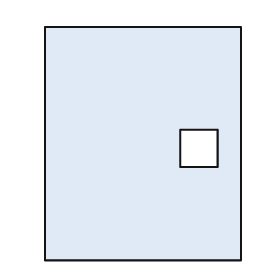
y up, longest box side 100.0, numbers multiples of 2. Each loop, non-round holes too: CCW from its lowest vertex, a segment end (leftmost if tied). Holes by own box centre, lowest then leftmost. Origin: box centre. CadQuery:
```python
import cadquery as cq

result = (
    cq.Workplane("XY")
    .moveTo(-42.0, -50.0)
    .lineTo(42.0, -50.0)
    .lineTo(42.0, 50.0)
    .lineTo(-42.0, 50.0)
    .close()
    .moveTo(16.0, -10.0)
    .lineTo(32.0, -10.0)
    .lineTo(32.0, 6.0)
    .lineTo(16.0, 6.0)
    .close()
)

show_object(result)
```